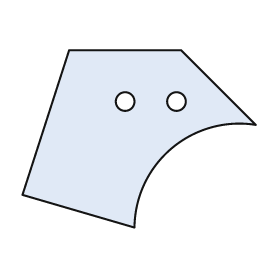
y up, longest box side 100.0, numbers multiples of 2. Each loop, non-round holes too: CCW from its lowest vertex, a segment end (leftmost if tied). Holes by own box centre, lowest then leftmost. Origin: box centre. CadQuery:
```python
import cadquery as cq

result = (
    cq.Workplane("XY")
    .moveTo(-2.0, -38.0)
    .threePointArc((14.0, -4.0), (50.0, 6.0))
    .lineTo(18.0, 38.0)
    .lineTo(-30.0, 38.0)
    .lineTo(-50.0, -24.0)
    .close()
    .moveTo(-6.0, 16.0)
    .circle(4.0)
    .moveTo(16.0, 16.0)
    .circle(4.0)
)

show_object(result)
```